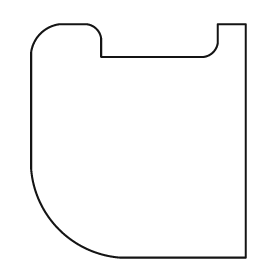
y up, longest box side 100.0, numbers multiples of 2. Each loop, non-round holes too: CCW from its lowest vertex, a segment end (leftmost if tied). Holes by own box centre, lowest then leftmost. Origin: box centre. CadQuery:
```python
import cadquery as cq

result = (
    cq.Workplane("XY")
    .moveTo(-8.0, -50.0)
    .lineTo(46.0, -50.0)
    .lineTo(46.0, 50.0)
    .lineTo(34.0, 50.0)
    .lineTo(34.0, 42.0)
    .threePointArc((32.0, 38.0), (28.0, 36.0))
    .lineTo(-16.0, 36.0)
    .lineTo(-16.0, 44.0)
    .threePointArc((-18.0, 48.0), (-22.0, 50.0))
    .lineTo(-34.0, 50.0)
    .threePointArc((-42.0, 46.0), (-46.0, 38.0))
    .lineTo(-46.0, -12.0)
    .threePointArc((-34.0, -38.0), (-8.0, -50.0))
    .close()
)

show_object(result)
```